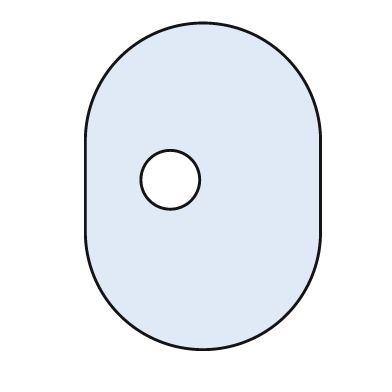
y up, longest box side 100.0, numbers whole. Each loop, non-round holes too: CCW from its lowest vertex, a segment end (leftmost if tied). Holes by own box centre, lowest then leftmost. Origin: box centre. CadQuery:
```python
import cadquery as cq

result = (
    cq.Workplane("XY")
    .moveTo(-36.0, -14.0)
    .threePointArc((0.0, -50.0), (36.0, -14.0))
    .lineTo(36.0, 14.0)
    .threePointArc((0.0, 50.0), (-36.0, 14.0))
    .close()
    .moveTo(-10.0, 2.0)
    .circle(9.0)
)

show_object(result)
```